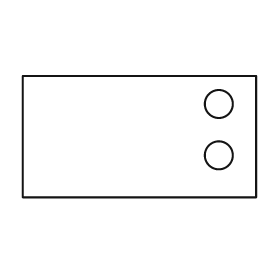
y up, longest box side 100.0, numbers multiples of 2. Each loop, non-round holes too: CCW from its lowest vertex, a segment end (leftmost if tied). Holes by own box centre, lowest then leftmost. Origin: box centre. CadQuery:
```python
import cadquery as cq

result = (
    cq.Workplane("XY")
    .moveTo(-50.0, -26.0)
    .lineTo(50.0, -26.0)
    .lineTo(50.0, 26.0)
    .lineTo(-50.0, 26.0)
    .close()
    .moveTo(34.0, -8.0)
    .circle(6.0)
    .moveTo(34.0, 14.0)
    .circle(6.0)
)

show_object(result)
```